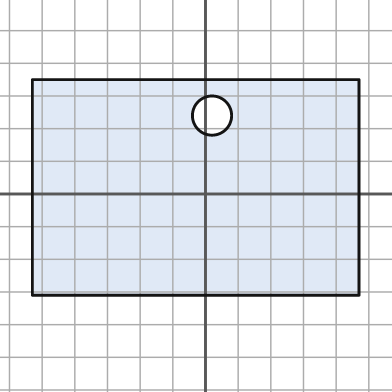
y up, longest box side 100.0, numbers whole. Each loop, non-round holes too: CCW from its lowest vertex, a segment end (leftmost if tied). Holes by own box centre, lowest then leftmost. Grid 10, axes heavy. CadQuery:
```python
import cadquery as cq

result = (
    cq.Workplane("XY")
    .moveTo(-53.0, -31.0)
    .lineTo(47.0, -31.0)
    .lineTo(47.0, 35.0)
    .lineTo(-53.0, 35.0)
    .close()
    .moveTo(2.0, 24.0)
    .circle(6.0)
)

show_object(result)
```